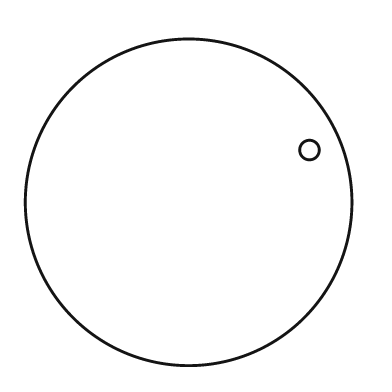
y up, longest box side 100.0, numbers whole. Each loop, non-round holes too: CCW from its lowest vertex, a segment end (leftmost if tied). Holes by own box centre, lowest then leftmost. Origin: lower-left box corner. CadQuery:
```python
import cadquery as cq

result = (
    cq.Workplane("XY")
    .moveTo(50.0, 50.0)
    .circle(50.0)
    .moveTo(87.0, 66.0)
    .circle(3.0)
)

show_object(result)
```